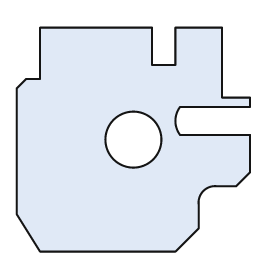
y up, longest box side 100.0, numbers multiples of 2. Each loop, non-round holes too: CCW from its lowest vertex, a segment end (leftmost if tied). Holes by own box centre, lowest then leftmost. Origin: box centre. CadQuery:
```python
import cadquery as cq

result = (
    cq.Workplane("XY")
    .moveTo(-40.0, -48.0)
    .lineTo(18.0, -48.0)
    .lineTo(28.0, -38.0)
    .lineTo(28.0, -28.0)
    .threePointArc((30.0, -22.0), (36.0, -20.0))
    .lineTo(44.0, -20.0)
    .lineTo(50.0, -14.0)
    .lineTo(50.0, 2.0)
    .lineTo(20.0, 2.0)
    .threePointArc((18.0, 8.0), (20.0, 14.0))
    .lineTo(50.0, 14.0)
    .lineTo(50.0, 18.0)
    .lineTo(38.0, 18.0)
    .lineTo(38.0, 48.0)
    .lineTo(18.0, 48.0)
    .lineTo(18.0, 32.0)
    .lineTo(8.0, 32.0)
    .lineTo(8.0, 48.0)
    .lineTo(-40.0, 48.0)
    .lineTo(-40.0, 26.0)
    .lineTo(-46.0, 26.0)
    .lineTo(-50.0, 22.0)
    .lineTo(-50.0, -32.0)
    .close()
    .moveTo(0.0, 0.0)
    .circle(12.0)
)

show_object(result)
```